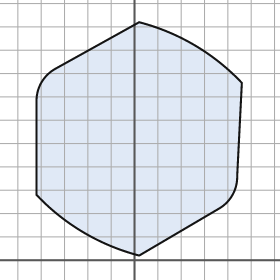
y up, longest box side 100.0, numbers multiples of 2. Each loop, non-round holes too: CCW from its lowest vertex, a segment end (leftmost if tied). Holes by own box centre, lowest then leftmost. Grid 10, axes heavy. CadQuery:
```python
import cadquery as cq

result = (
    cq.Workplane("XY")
    .moveTo(2.0, 2.0)
    .lineTo(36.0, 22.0)
    .threePointArc((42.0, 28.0), (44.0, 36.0))
    .lineTo(46.0, 76.0)
    .threePointArc((26.0, 92.0), (2.0, 102.0))
    .lineTo(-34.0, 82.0)
    .threePointArc((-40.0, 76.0), (-42.0, 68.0))
    .lineTo(-42.0, 28.0)
    .threePointArc((-22.0, 12.0), (2.0, 2.0))
    .close()
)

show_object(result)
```